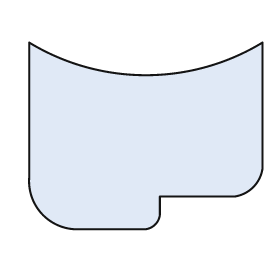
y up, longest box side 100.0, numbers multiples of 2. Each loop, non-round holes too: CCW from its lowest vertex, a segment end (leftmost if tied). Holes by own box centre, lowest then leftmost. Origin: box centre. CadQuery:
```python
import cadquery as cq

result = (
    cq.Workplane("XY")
    .moveTo(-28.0, -40.0)
    .lineTo(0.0, -40.0)
    .threePointArc((4.0, -38.0), (6.0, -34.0))
    .lineTo(6.0, -26.0)
    .lineTo(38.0, -26.0)
    .threePointArc((46.0, -22.0), (50.0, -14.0))
    .lineTo(50.0, 40.0)
    .threePointArc((0.0, 26.0), (-50.0, 40.0))
    .lineTo(-50.0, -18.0)
    .threePointArc((-44.0, -34.0), (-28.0, -40.0))
    .close()
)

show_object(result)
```